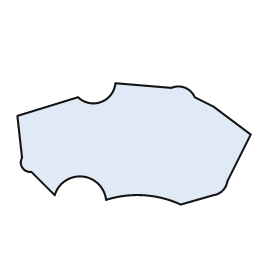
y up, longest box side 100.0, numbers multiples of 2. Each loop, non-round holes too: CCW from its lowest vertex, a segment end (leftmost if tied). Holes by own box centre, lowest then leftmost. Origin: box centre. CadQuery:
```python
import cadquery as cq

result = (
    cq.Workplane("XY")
    .moveTo(20.0, -26.0)
    .lineTo(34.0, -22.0)
    .threePointArc((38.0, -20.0), (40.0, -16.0))
    .lineTo(50.0, 4.0)
    .lineTo(34.0, 16.0)
    .lineTo(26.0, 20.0)
    .threePointArc((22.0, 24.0), (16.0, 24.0))
    .lineTo(-8.0, 26.0)
    .threePointArc((-14.0, 18.0), (-24.0, 20.0))
    .lineTo(-50.0, 12.0)
    .lineTo(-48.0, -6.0)
    .threePointArc((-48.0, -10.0), (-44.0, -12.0))
    .lineTo(-34.0, -22.0)
    .threePointArc((-22.0, -14.0), (-12.0, -24.0))
    .threePointArc((4.0, -22.0), (20.0, -26.0))
    .close()
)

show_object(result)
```